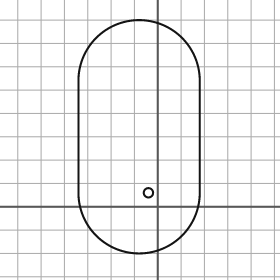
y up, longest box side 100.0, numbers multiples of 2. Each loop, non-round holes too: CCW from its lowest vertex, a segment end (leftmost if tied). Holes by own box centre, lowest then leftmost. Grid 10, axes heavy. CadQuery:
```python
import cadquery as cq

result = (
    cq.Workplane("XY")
    .moveTo(-34.0, 6.0)
    .threePointArc((-8.0, -20.0), (18.0, 6.0))
    .lineTo(18.0, 54.0)
    .threePointArc((-8.0, 80.0), (-34.0, 54.0))
    .close()
    .moveTo(-4.0, 6.0)
    .circle(2.0)
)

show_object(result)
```